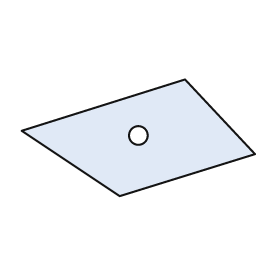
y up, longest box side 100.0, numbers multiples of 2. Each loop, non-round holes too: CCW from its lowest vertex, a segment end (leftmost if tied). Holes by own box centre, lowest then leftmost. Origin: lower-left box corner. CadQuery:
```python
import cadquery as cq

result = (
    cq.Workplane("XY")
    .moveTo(42.0, 0.0)
    .lineTo(100.0, 18.0)
    .lineTo(70.0, 50.0)
    .lineTo(0.0, 28.0)
    .close()
    .moveTo(50.0, 26.0)
    .circle(4.0)
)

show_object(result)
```